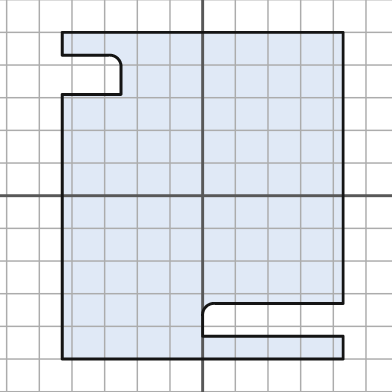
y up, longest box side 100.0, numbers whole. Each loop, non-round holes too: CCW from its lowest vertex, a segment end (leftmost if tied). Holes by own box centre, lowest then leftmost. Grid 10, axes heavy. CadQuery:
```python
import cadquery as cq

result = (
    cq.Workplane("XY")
    .moveTo(-43.0, -50.0)
    .lineTo(43.0, -50.0)
    .lineTo(43.0, -43.0)
    .lineTo(0.0, -43.0)
    .lineTo(0.0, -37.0)
    .threePointArc((1.0, -34.0), (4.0, -33.0))
    .lineTo(43.0, -33.0)
    .lineTo(43.0, 50.0)
    .lineTo(-43.0, 50.0)
    .lineTo(-43.0, 43.0)
    .lineTo(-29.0, 43.0)
    .threePointArc((-26.0, 42.0), (-25.0, 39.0))
    .lineTo(-25.0, 31.0)
    .lineTo(-43.0, 31.0)
    .close()
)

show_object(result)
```